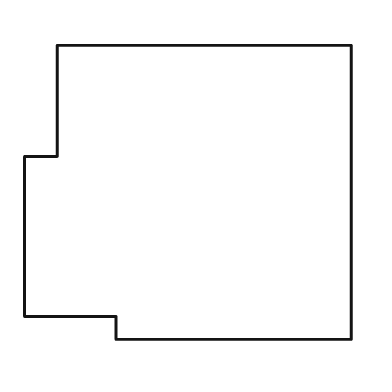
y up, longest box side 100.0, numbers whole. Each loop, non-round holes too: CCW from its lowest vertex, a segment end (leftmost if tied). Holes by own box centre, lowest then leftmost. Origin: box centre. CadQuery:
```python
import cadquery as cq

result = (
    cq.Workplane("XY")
    .moveTo(-22.0, -45.0)
    .lineTo(50.0, -45.0)
    .lineTo(50.0, 45.0)
    .lineTo(-40.0, 45.0)
    .lineTo(-40.0, 11.0)
    .lineTo(-50.0, 11.0)
    .lineTo(-50.0, -38.0)
    .lineTo(-22.0, -38.0)
    .close()
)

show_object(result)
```